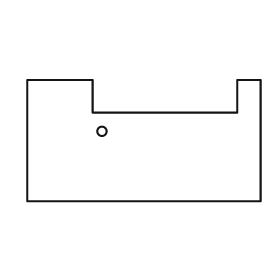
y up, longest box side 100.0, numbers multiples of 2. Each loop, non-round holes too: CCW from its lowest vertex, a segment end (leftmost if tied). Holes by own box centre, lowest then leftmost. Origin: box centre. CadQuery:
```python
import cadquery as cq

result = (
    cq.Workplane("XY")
    .moveTo(-50.0, -26.0)
    .lineTo(50.0, -26.0)
    .lineTo(50.0, 26.0)
    .lineTo(40.0, 26.0)
    .lineTo(40.0, 12.0)
    .lineTo(-22.0, 12.0)
    .lineTo(-22.0, 26.0)
    .lineTo(-50.0, 26.0)
    .close()
    .moveTo(-18.0, 4.0)
    .circle(2.0)
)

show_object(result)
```